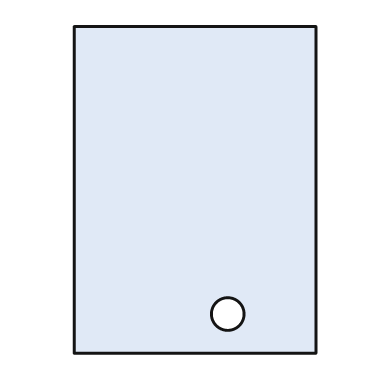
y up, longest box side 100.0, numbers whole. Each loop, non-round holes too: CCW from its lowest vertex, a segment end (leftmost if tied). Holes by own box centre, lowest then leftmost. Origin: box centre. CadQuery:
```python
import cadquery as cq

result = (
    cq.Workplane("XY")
    .moveTo(-37.0, -50.0)
    .lineTo(37.0, -50.0)
    .lineTo(37.0, 50.0)
    .lineTo(-37.0, 50.0)
    .close()
    .moveTo(10.0, -38.0)
    .circle(5.0)
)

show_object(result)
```